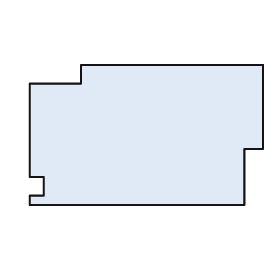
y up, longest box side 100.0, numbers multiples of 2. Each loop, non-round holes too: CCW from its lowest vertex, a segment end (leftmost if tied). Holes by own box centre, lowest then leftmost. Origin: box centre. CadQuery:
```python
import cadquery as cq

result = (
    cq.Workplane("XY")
    .moveTo(-50.0, -30.0)
    .lineTo(42.0, -30.0)
    .lineTo(42.0, -6.0)
    .lineTo(50.0, -6.0)
    .lineTo(50.0, 30.0)
    .lineTo(-28.0, 30.0)
    .lineTo(-28.0, 22.0)
    .lineTo(-50.0, 22.0)
    .lineTo(-50.0, -18.0)
    .lineTo(-44.0, -18.0)
    .lineTo(-44.0, -26.0)
    .lineTo(-50.0, -26.0)
    .close()
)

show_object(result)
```